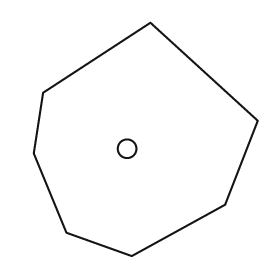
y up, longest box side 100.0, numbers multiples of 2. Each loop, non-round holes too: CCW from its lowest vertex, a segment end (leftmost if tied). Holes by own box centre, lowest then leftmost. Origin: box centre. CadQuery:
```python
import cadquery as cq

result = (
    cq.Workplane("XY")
    .moveTo(-6.0, -50.0)
    .lineTo(34.0, -28.0)
    .lineTo(48.0, 8.0)
    .lineTo(2.0, 50.0)
    .lineTo(-44.0, 20.0)
    .lineTo(-48.0, -6.0)
    .lineTo(-34.0, -40.0)
    .close()
    .moveTo(-8.0, -4.0)
    .circle(4.0)
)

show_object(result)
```